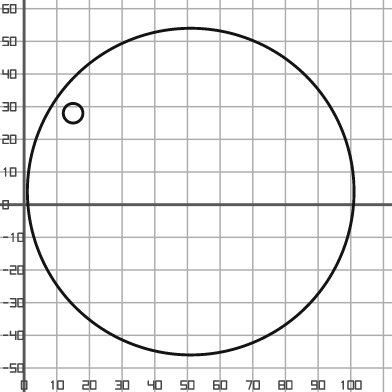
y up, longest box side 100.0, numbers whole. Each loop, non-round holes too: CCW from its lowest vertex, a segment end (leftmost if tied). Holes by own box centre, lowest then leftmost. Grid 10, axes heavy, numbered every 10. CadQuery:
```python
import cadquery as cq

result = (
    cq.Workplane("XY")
    .moveTo(51.0, 4.0)
    .circle(50.0)
    .moveTo(15.0, 28.0)
    .circle(3.0)
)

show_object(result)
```